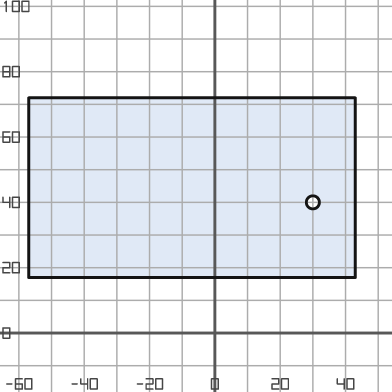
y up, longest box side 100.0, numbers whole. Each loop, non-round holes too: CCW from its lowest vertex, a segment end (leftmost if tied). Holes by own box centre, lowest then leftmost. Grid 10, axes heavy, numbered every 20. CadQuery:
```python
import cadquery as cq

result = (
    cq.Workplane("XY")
    .moveTo(-57.0, 17.0)
    .lineTo(43.0, 17.0)
    .lineTo(43.0, 72.0)
    .lineTo(-57.0, 72.0)
    .close()
    .moveTo(30.0, 40.0)
    .circle(2.0)
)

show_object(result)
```